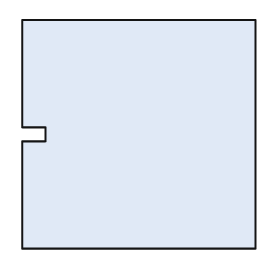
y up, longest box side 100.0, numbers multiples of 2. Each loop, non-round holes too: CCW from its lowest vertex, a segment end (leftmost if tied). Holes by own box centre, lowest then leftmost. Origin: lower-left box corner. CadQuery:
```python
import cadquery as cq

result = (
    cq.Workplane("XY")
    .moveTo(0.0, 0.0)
    .lineTo(100.0, 0.0)
    .lineTo(100.0, 98.0)
    .lineTo(0.0, 98.0)
    .lineTo(0.0, 52.0)
    .lineTo(10.0, 52.0)
    .lineTo(10.0, 46.0)
    .lineTo(0.0, 46.0)
    .close()
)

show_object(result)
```